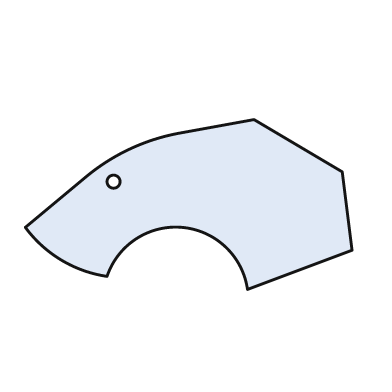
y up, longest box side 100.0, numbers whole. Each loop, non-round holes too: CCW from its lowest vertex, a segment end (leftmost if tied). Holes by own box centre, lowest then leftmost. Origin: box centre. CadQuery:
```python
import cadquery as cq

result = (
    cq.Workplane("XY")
    .moveTo(18.0, -26.0)
    .lineTo(50.0, -14.0)
    .lineTo(47.0, 10.0)
    .lineTo(20.0, 26.0)
    .lineTo(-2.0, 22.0)
    .threePointArc((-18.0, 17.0), (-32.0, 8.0))
    .lineTo(-50.0, -7.0)
    .threePointArc((-39.0, -17.0), (-25.0, -22.0))
    .threePointArc((-2.0, -7.0), (18.0, -26.0))
    .close()
    .moveTo(-23.0, 7.0)
    .circle(2.0)
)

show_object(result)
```